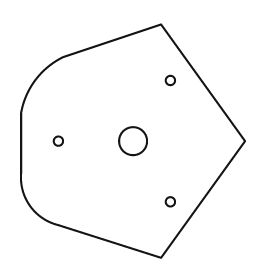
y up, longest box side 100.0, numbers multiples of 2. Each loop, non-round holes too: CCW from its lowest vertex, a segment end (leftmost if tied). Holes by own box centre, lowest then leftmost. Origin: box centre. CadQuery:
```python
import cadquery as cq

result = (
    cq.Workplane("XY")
    .moveTo(12.0, -50.0)
    .lineTo(48.0, 0.0)
    .lineTo(12.0, 50.0)
    .lineTo(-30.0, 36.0)
    .threePointArc((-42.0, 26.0), (-48.0, 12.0))
    .lineTo(-48.0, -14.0)
    .threePointArc((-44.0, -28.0), (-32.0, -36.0))
    .close()
    .moveTo(16.0, -26.0)
    .circle(2.0)
    .moveTo(-32.0, 0.0)
    .circle(2.0)
    .moveTo(0.0, 0.0)
    .circle(6.0)
    .moveTo(16.0, 26.0)
    .circle(2.0)
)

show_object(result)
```